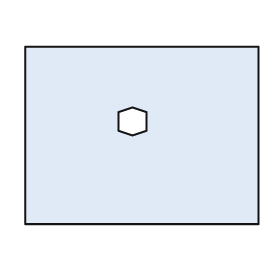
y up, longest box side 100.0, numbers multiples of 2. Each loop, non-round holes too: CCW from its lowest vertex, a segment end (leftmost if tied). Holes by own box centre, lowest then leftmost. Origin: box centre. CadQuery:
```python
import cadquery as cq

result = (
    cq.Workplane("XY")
    .moveTo(-50.0, -38.0)
    .lineTo(50.0, -38.0)
    .lineTo(50.0, 38.0)
    .lineTo(-50.0, 38.0)
    .close()
    .moveTo(-4.0, 0.0)
    .lineTo(2.0, 2.0)
    .lineTo(2.0, 10.0)
    .lineTo(-4.0, 12.0)
    .lineTo(-10.0, 10.0)
    .lineTo(-10.0, 2.0)
    .close()
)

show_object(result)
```